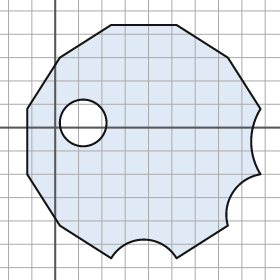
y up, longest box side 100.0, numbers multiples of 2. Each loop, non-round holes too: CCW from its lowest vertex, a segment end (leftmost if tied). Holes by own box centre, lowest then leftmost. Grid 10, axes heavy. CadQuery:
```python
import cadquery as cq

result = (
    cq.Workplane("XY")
    .moveTo(24.0, -56.0)
    .threePointArc((38.0, -48.0), (52.0, -56.0))
    .lineTo(74.0, -42.0)
    .threePointArc((76.0, -28.0), (88.0, -20.0))
    .threePointArc((84.0, -6.0), (88.0, 8.0))
    .lineTo(74.0, 30.0)
    .lineTo(52.0, 44.0)
    .lineTo(24.0, 44.0)
    .lineTo(2.0, 30.0)
    .lineTo(-12.0, 8.0)
    .lineTo(-12.0, -20.0)
    .lineTo(2.0, -42.0)
    .close()
    .moveTo(12.0, 2.0)
    .circle(10.0)
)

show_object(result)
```